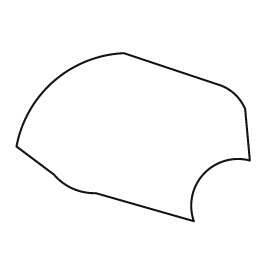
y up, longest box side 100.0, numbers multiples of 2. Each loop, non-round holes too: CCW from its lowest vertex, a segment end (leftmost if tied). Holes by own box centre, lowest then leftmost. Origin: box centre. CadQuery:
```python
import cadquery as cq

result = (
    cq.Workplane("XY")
    .moveTo(26.0, -36.0)
    .threePointArc((30.0, -16.0), (50.0, -10.0))
    .lineTo(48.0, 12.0)
    .threePointArc((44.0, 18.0), (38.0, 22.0))
    .lineTo(-4.0, 36.0)
    .threePointArc((-34.0, 24.0), (-50.0, -4.0))
    .lineTo(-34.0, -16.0)
    .threePointArc((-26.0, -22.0), (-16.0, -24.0))
    .close()
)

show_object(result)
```